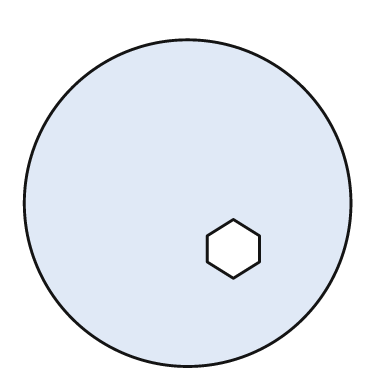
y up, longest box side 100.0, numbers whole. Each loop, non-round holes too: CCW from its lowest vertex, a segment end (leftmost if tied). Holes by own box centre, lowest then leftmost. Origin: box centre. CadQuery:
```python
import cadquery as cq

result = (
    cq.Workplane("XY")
    .moveTo(0.0, 0.0)
    .circle(50.0)
    .moveTo(14.0, -23.0)
    .lineTo(22.0, -18.0)
    .lineTo(22.0, -10.0)
    .lineTo(14.0, -5.0)
    .lineTo(6.0, -10.0)
    .lineTo(6.0, -18.0)
    .close()
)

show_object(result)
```